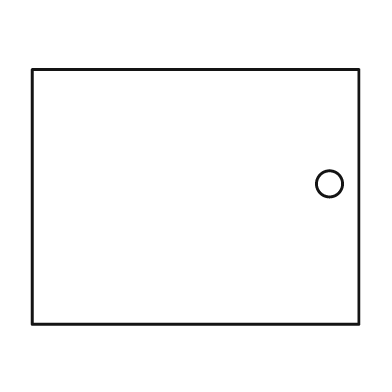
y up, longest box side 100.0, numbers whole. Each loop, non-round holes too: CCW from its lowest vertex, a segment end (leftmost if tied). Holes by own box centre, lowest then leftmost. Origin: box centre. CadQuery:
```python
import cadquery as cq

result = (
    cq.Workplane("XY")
    .moveTo(-50.0, -39.0)
    .lineTo(50.0, -39.0)
    .lineTo(50.0, 39.0)
    .lineTo(-50.0, 39.0)
    .close()
    .moveTo(41.0, 4.0)
    .circle(4.0)
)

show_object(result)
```